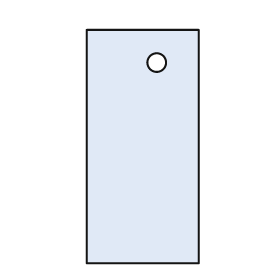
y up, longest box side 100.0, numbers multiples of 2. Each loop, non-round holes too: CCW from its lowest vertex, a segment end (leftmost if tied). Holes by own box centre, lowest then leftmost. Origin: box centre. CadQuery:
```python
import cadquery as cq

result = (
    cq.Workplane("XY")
    .moveTo(-24.0, -50.0)
    .lineTo(24.0, -50.0)
    .lineTo(24.0, 50.0)
    .lineTo(-24.0, 50.0)
    .close()
    .moveTo(6.0, 36.0)
    .circle(4.0)
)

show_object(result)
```